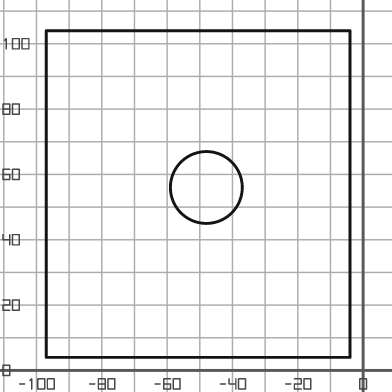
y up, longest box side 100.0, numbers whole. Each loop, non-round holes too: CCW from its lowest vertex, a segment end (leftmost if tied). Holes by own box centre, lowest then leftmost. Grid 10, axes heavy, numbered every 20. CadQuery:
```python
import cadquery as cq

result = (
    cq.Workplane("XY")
    .moveTo(-97.0, 4.0)
    .lineTo(-4.0, 4.0)
    .lineTo(-4.0, 104.0)
    .lineTo(-97.0, 104.0)
    .close()
    .moveTo(-48.0, 56.0)
    .circle(11.0)
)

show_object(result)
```